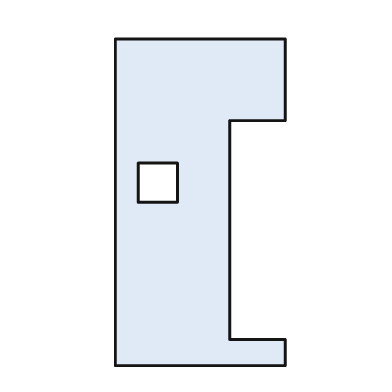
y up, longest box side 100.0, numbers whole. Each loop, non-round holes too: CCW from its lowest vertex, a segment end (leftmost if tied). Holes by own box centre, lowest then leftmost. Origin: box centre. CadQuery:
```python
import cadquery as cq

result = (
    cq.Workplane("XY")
    .moveTo(-26.0, -50.0)
    .lineTo(26.0, -50.0)
    .lineTo(26.0, -42.0)
    .lineTo(9.0, -42.0)
    .lineTo(9.0, 25.0)
    .lineTo(26.0, 25.0)
    .lineTo(26.0, 50.0)
    .lineTo(-26.0, 50.0)
    .close()
    .moveTo(-19.0, 0.0)
    .lineTo(-7.0, 0.0)
    .lineTo(-7.0, 12.0)
    .lineTo(-19.0, 12.0)
    .close()
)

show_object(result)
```